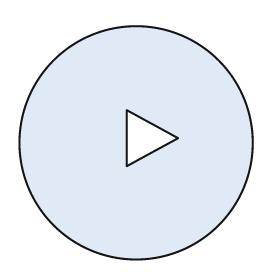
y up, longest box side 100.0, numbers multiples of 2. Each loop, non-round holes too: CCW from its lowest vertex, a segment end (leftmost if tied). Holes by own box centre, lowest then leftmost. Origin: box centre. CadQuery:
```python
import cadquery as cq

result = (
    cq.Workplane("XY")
    .moveTo(0.0, 0.0)
    .circle(50.0)
    .moveTo(-4.0, -10.0)
    .lineTo(18.0, 2.0)
    .lineTo(-4.0, 14.0)
    .close()
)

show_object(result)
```